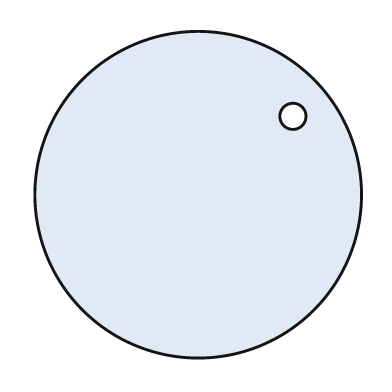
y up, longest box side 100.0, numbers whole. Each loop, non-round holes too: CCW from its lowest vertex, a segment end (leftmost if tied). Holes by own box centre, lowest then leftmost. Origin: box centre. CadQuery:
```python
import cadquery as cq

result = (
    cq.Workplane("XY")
    .moveTo(0.0, 0.0)
    .circle(50.0)
    .moveTo(29.0, 24.0)
    .circle(4.0)
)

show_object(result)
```